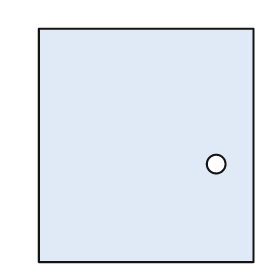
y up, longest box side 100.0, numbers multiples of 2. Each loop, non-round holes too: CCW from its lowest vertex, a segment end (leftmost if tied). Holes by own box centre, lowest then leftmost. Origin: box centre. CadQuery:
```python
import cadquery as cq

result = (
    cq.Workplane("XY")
    .moveTo(-46.0, -50.0)
    .lineTo(46.0, -50.0)
    .lineTo(46.0, 50.0)
    .lineTo(-46.0, 50.0)
    .close()
    .moveTo(30.0, -8.0)
    .circle(4.0)
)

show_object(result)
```